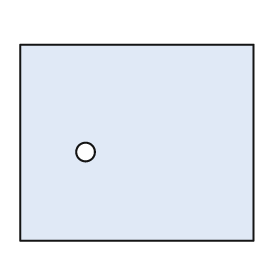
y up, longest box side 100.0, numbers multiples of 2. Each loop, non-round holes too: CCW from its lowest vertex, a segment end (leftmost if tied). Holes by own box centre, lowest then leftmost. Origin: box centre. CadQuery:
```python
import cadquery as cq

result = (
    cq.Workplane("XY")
    .moveTo(-50.0, -42.0)
    .lineTo(50.0, -42.0)
    .lineTo(50.0, 42.0)
    .lineTo(-50.0, 42.0)
    .close()
    .moveTo(-22.0, -4.0)
    .circle(4.0)
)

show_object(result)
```